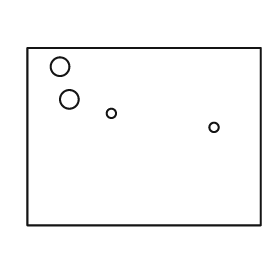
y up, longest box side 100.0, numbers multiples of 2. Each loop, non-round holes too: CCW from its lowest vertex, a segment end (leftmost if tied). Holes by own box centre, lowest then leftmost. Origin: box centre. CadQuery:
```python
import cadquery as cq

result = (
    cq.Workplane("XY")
    .moveTo(-50.0, -38.0)
    .lineTo(50.0, -38.0)
    .lineTo(50.0, 38.0)
    .lineTo(-50.0, 38.0)
    .close()
    .moveTo(30.0, 4.0)
    .circle(2.0)
    .moveTo(-14.0, 10.0)
    .circle(2.0)
    .moveTo(-32.0, 16.0)
    .circle(4.0)
    .moveTo(-36.0, 30.0)
    .circle(4.0)
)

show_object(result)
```